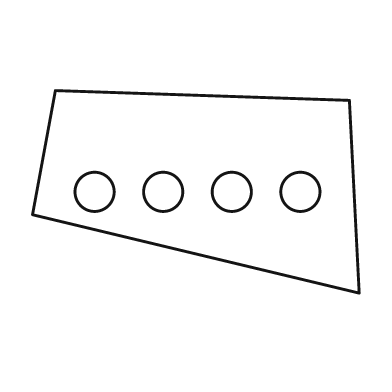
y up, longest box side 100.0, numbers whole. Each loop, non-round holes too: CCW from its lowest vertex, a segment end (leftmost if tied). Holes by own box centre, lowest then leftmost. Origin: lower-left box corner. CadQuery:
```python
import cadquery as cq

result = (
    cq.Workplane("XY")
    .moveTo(100.0, 0.0)
    .lineTo(97.0, 59.0)
    .lineTo(7.0, 62.0)
    .lineTo(0.0, 24.0)
    .close()
    .moveTo(19.0, 31.0)
    .circle(6.0)
    .moveTo(40.0, 31.0)
    .circle(6.0)
    .moveTo(61.0, 31.0)
    .circle(6.0)
    .moveTo(82.0, 31.0)
    .circle(6.0)
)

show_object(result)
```